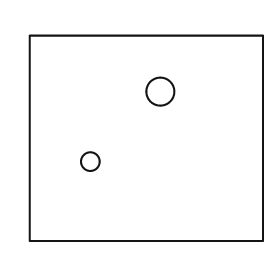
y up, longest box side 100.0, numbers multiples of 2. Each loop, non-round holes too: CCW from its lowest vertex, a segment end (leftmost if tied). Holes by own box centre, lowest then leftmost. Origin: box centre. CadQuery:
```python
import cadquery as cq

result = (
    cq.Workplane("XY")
    .moveTo(-50.0, -44.0)
    .lineTo(50.0, -44.0)
    .lineTo(50.0, 44.0)
    .lineTo(-50.0, 44.0)
    .close()
    .moveTo(-24.0, -10.0)
    .circle(4.0)
    .moveTo(6.0, 20.0)
    .circle(6.0)
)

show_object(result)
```